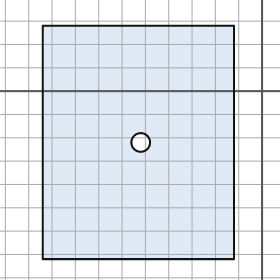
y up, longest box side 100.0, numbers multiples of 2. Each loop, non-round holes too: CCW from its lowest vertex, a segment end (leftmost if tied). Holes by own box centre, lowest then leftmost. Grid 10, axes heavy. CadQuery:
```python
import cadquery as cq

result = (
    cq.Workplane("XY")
    .moveTo(-94.0, -72.0)
    .lineTo(-12.0, -72.0)
    .lineTo(-12.0, 28.0)
    .lineTo(-94.0, 28.0)
    .close()
    .moveTo(-52.0, -22.0)
    .circle(4.0)
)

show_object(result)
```